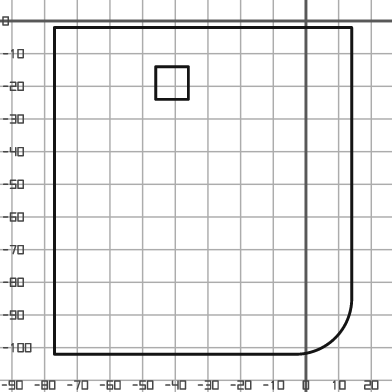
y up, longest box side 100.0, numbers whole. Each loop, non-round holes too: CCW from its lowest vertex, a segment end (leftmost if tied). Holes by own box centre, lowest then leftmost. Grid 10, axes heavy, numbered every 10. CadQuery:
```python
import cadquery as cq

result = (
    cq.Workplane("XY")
    .moveTo(-77.0, -102.0)
    .lineTo(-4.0, -102.0)
    .threePointArc((9.0, -97.0), (14.0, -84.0))
    .lineTo(14.0, -2.0)
    .lineTo(-77.0, -2.0)
    .close()
    .moveTo(-46.0, -24.0)
    .lineTo(-36.0, -24.0)
    .lineTo(-36.0, -14.0)
    .lineTo(-46.0, -14.0)
    .close()
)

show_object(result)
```